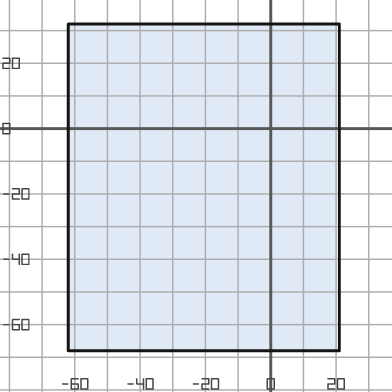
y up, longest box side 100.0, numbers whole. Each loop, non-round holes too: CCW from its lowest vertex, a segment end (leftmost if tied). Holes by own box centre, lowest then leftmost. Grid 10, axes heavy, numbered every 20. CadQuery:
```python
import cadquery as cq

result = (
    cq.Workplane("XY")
    .moveTo(-62.0, -68.0)
    .lineTo(21.0, -68.0)
    .lineTo(21.0, 32.0)
    .lineTo(-62.0, 32.0)
    .close()
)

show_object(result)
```